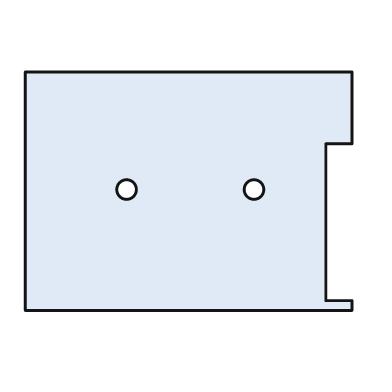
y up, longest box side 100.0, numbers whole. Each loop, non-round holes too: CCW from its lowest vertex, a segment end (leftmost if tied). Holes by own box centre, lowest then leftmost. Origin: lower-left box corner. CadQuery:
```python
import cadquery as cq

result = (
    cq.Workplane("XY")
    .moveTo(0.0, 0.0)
    .lineTo(100.0, 0.0)
    .lineTo(100.0, 3.0)
    .lineTo(92.0, 3.0)
    .lineTo(92.0, 51.0)
    .lineTo(100.0, 51.0)
    .lineTo(100.0, 73.0)
    .lineTo(0.0, 73.0)
    .close()
    .moveTo(31.0, 37.0)
    .circle(3.0)
    .moveTo(70.0, 37.0)
    .circle(3.0)
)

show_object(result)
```